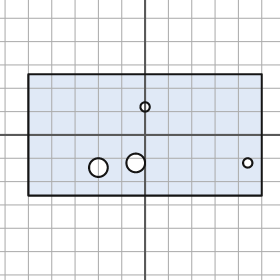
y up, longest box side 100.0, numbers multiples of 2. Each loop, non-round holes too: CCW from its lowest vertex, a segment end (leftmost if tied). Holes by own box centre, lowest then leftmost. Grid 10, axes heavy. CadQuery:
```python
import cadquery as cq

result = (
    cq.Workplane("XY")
    .moveTo(-50.0, -26.0)
    .lineTo(50.0, -26.0)
    .lineTo(50.0, 26.0)
    .lineTo(-50.0, 26.0)
    .close()
    .moveTo(-20.0, -14.0)
    .circle(4.0)
    .moveTo(-4.0, -12.0)
    .circle(4.0)
    .moveTo(44.0, -12.0)
    .circle(2.0)
    .moveTo(0.0, 12.0)
    .circle(2.0)
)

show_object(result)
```